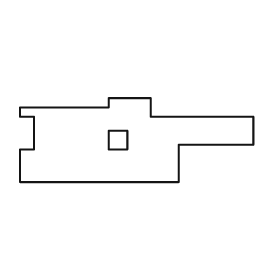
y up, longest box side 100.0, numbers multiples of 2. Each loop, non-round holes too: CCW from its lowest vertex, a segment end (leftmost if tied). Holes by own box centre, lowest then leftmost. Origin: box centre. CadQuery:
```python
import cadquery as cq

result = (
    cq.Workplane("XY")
    .moveTo(-50.0, -18.0)
    .lineTo(18.0, -18.0)
    .lineTo(18.0, -2.0)
    .lineTo(50.0, -2.0)
    .lineTo(50.0, 10.0)
    .lineTo(6.0, 10.0)
    .lineTo(6.0, 18.0)
    .lineTo(-12.0, 18.0)
    .lineTo(-12.0, 14.0)
    .lineTo(-50.0, 14.0)
    .lineTo(-50.0, 10.0)
    .lineTo(-44.0, 10.0)
    .lineTo(-44.0, -4.0)
    .lineTo(-50.0, -4.0)
    .close()
    .moveTo(-12.0, -4.0)
    .lineTo(-4.0, -4.0)
    .lineTo(-4.0, 4.0)
    .lineTo(-12.0, 4.0)
    .close()
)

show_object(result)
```